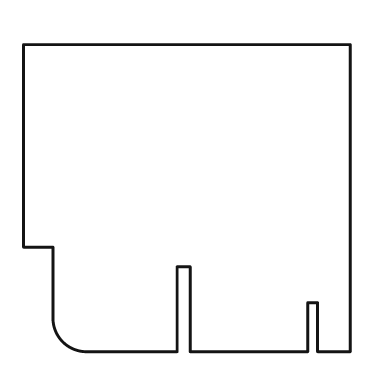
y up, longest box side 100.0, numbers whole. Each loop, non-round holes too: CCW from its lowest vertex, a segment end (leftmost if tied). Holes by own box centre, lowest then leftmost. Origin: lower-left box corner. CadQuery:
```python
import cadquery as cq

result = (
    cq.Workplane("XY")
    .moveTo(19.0, 0.0)
    .lineTo(47.0, 0.0)
    .lineTo(47.0, 26.0)
    .lineTo(51.0, 26.0)
    .lineTo(51.0, 0.0)
    .lineTo(87.0, 0.0)
    .lineTo(87.0, 15.0)
    .lineTo(90.0, 15.0)
    .lineTo(90.0, 0.0)
    .lineTo(100.0, 0.0)
    .lineTo(100.0, 94.0)
    .lineTo(0.0, 94.0)
    .lineTo(0.0, 32.0)
    .lineTo(9.0, 32.0)
    .lineTo(9.0, 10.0)
    .threePointArc((12.0, 3.0), (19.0, 0.0))
    .close()
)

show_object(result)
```